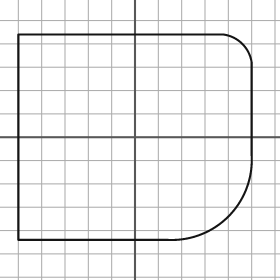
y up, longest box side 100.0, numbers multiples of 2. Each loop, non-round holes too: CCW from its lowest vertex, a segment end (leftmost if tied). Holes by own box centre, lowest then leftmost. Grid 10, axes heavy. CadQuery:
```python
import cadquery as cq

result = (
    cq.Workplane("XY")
    .moveTo(-50.0, -44.0)
    .lineTo(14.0, -44.0)
    .threePointArc((40.0, -34.0), (50.0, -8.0))
    .lineTo(50.0, 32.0)
    .threePointArc((46.0, 40.0), (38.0, 44.0))
    .lineTo(-50.0, 44.0)
    .close()
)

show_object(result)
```